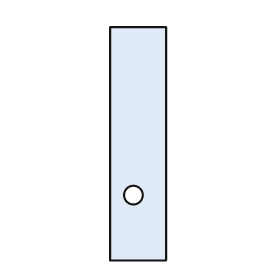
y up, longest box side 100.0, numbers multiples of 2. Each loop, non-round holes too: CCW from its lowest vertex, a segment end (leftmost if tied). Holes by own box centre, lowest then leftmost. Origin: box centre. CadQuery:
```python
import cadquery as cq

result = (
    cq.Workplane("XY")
    .moveTo(-12.0, -50.0)
    .lineTo(12.0, -50.0)
    .lineTo(12.0, 50.0)
    .lineTo(-12.0, 50.0)
    .close()
    .moveTo(-2.0, -22.0)
    .circle(4.0)
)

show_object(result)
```